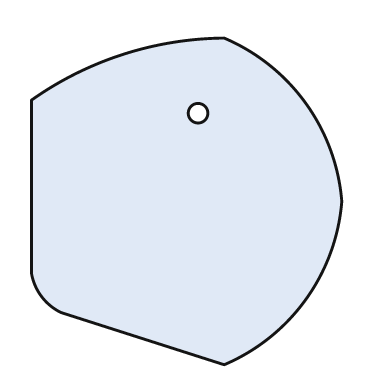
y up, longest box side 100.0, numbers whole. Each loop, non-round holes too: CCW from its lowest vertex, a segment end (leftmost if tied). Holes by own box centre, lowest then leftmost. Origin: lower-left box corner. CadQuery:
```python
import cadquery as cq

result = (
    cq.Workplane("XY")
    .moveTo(59.0, 0.0)
    .threePointArc((84.0, 20.0), (95.0, 50.0))
    .threePointArc((84.0, 80.0), (59.0, 100.0))
    .threePointArc((28.0, 95.0), (0.0, 81.0))
    .lineTo(0.0, 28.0)
    .threePointArc((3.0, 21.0), (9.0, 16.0))
    .close()
    .moveTo(51.0, 77.0)
    .circle(3.0)
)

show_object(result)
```